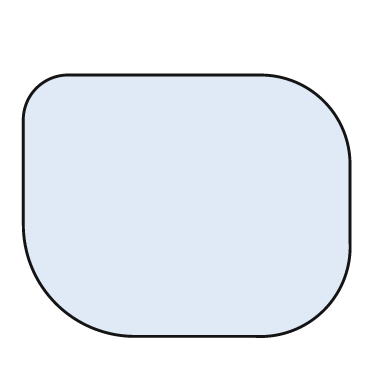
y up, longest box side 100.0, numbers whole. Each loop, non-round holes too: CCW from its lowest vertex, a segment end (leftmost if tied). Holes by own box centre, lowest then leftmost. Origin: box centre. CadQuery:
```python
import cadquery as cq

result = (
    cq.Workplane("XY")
    .moveTo(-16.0, -40.0)
    .lineTo(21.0, -40.0)
    .threePointArc((42.0, -32.0), (50.0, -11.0))
    .lineTo(50.0, 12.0)
    .threePointArc((42.0, 32.0), (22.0, 40.0))
    .lineTo(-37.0, 40.0)
    .threePointArc((-46.0, 36.0), (-50.0, 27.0))
    .lineTo(-50.0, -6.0)
    .threePointArc((-40.0, -30.0), (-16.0, -40.0))
    .close()
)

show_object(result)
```